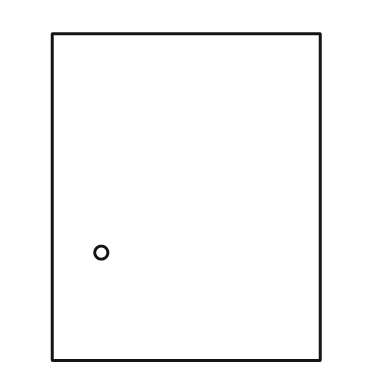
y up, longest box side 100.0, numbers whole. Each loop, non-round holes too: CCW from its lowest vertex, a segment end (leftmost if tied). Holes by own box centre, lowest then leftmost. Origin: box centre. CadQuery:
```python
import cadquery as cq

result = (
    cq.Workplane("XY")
    .moveTo(-41.0, -50.0)
    .lineTo(41.0, -50.0)
    .lineTo(41.0, 50.0)
    .lineTo(-41.0, 50.0)
    .close()
    .moveTo(-26.0, -17.0)
    .circle(2.0)
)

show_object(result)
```